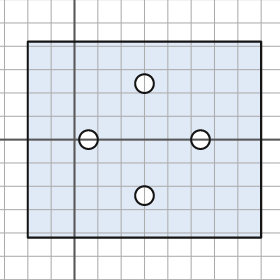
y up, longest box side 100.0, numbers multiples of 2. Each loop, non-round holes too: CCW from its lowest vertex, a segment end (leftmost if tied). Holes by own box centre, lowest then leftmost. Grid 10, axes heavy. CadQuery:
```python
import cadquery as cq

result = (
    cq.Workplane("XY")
    .moveTo(-20.0, -42.0)
    .lineTo(80.0, -42.0)
    .lineTo(80.0, 42.0)
    .lineTo(-20.0, 42.0)
    .close()
    .moveTo(30.0, -24.0)
    .circle(4.0)
    .moveTo(6.0, 0.0)
    .circle(4.0)
    .moveTo(54.0, 0.0)
    .circle(4.0)
    .moveTo(30.0, 24.0)
    .circle(4.0)
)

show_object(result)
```